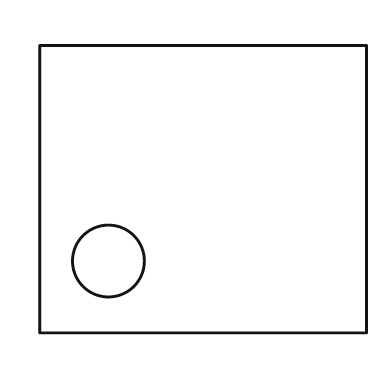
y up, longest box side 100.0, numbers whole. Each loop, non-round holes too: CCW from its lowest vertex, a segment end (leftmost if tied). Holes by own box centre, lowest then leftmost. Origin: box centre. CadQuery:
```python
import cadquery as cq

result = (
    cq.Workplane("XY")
    .moveTo(-50.0, -44.0)
    .lineTo(50.0, -44.0)
    .lineTo(50.0, 44.0)
    .lineTo(-50.0, 44.0)
    .close()
    .moveTo(-29.0, -22.0)
    .circle(11.0)
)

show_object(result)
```